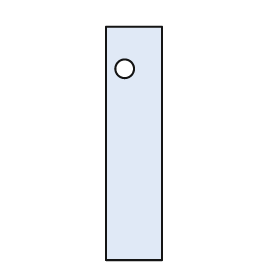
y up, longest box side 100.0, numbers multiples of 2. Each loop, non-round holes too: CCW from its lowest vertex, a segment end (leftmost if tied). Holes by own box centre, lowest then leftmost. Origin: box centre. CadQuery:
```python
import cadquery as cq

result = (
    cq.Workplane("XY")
    .moveTo(-12.0, -50.0)
    .lineTo(12.0, -50.0)
    .lineTo(12.0, 50.0)
    .lineTo(-12.0, 50.0)
    .close()
    .moveTo(-4.0, 32.0)
    .circle(4.0)
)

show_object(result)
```